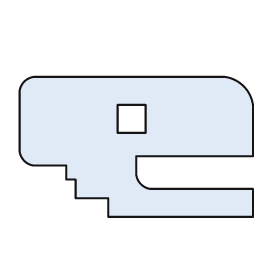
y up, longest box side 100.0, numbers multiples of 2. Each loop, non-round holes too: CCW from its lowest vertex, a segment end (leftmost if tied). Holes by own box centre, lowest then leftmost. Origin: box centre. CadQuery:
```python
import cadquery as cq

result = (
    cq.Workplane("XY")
    .moveTo(-12.0, -30.0)
    .lineTo(50.0, -30.0)
    .lineTo(50.0, -18.0)
    .lineTo(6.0, -18.0)
    .threePointArc((2.0, -16.0), (0.0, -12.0))
    .lineTo(0.0, -4.0)
    .lineTo(50.0, -4.0)
    .lineTo(50.0, 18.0)
    .threePointArc((46.0, 26.0), (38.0, 30.0))
    .lineTo(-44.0, 30.0)
    .threePointArc((-48.0, 28.0), (-50.0, 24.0))
    .lineTo(-50.0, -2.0)
    .threePointArc((-48.0, -6.0), (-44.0, -8.0))
    .lineTo(-30.0, -8.0)
    .lineTo(-30.0, -14.0)
    .lineTo(-26.0, -14.0)
    .lineTo(-26.0, -22.0)
    .lineTo(-12.0, -22.0)
    .close()
    .moveTo(-8.0, 6.0)
    .lineTo(4.0, 6.0)
    .lineTo(4.0, 18.0)
    .lineTo(-8.0, 18.0)
    .close()
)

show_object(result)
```